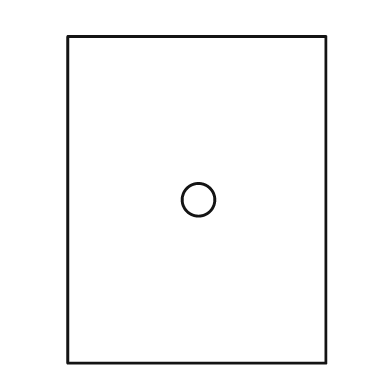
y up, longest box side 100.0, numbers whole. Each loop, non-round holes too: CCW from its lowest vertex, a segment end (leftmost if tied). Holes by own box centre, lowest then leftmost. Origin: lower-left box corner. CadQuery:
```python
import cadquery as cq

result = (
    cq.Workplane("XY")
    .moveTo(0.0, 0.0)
    .lineTo(79.0, 0.0)
    .lineTo(79.0, 100.0)
    .lineTo(0.0, 100.0)
    .close()
    .moveTo(40.0, 50.0)
    .circle(5.0)
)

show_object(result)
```